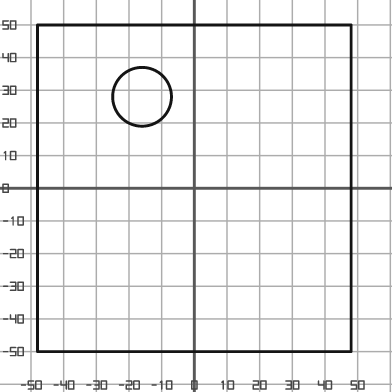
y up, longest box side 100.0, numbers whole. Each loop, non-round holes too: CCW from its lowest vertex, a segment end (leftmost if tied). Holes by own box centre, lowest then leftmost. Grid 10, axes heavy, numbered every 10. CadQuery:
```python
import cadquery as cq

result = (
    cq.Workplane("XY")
    .moveTo(-48.0, -50.0)
    .lineTo(48.0, -50.0)
    .lineTo(48.0, 50.0)
    .lineTo(-48.0, 50.0)
    .close()
    .moveTo(-16.0, 28.0)
    .circle(9.0)
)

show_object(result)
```